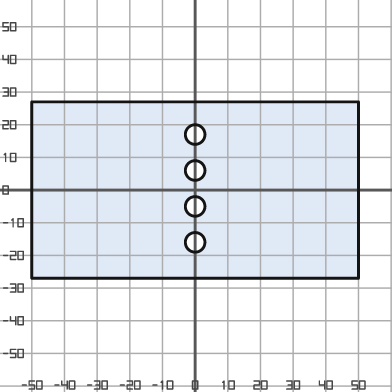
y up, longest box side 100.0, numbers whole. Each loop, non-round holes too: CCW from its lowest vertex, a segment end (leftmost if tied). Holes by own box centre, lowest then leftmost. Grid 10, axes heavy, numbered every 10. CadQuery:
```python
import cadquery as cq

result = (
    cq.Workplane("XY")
    .moveTo(-50.0, -27.0)
    .lineTo(50.0, -27.0)
    .lineTo(50.0, 27.0)
    .lineTo(-50.0, 27.0)
    .close()
    .moveTo(0.0, -16.0)
    .circle(3.0)
    .moveTo(0.0, -5.0)
    .circle(3.0)
    .moveTo(0.0, 6.0)
    .circle(3.0)
    .moveTo(0.0, 17.0)
    .circle(3.0)
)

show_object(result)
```